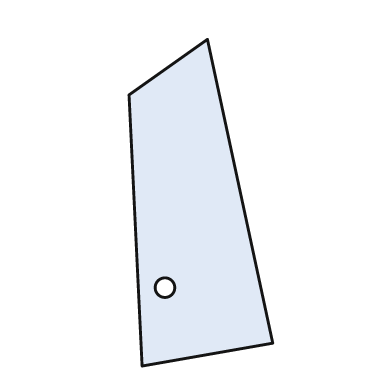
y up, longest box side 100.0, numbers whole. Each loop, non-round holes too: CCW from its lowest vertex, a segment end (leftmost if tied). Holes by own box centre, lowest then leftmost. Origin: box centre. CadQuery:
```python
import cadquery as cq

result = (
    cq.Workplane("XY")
    .moveTo(-18.0, -50.0)
    .lineTo(22.0, -43.0)
    .lineTo(2.0, 50.0)
    .lineTo(-22.0, 33.0)
    .close()
    .moveTo(-11.0, -26.0)
    .circle(3.0)
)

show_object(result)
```